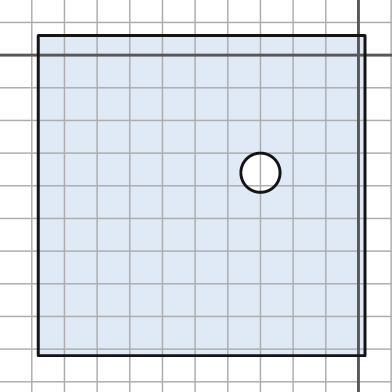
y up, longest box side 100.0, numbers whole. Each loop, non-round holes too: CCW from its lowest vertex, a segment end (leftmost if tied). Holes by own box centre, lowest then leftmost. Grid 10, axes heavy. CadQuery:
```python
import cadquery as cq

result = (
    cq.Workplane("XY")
    .moveTo(-98.0, -92.0)
    .lineTo(2.0, -92.0)
    .lineTo(2.0, 6.0)
    .lineTo(-98.0, 6.0)
    .close()
    .moveTo(-30.0, -36.0)
    .circle(6.0)
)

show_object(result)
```